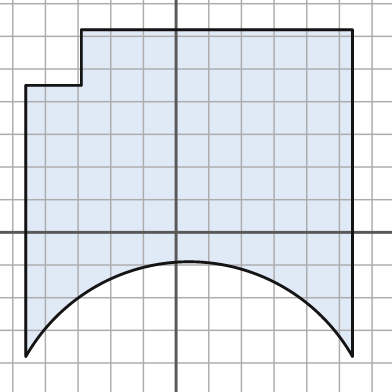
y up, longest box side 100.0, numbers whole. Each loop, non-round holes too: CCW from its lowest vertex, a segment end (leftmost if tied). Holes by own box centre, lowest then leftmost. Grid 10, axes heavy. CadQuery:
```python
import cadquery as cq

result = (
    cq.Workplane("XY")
    .moveTo(-46.0, -38.0)
    .threePointArc((4.0, -9.0), (54.0, -38.0))
    .lineTo(54.0, 62.0)
    .lineTo(-29.0, 62.0)
    .lineTo(-29.0, 45.0)
    .lineTo(-46.0, 45.0)
    .close()
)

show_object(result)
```